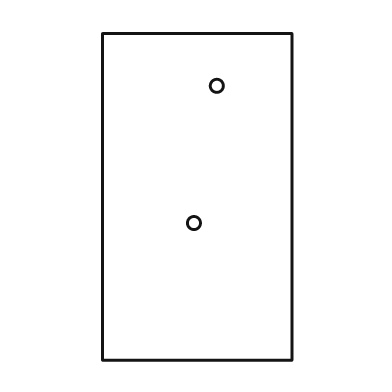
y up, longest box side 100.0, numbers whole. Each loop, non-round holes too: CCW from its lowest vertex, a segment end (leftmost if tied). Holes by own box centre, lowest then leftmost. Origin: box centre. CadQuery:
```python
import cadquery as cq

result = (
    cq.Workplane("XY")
    .moveTo(-29.0, -50.0)
    .lineTo(29.0, -50.0)
    .lineTo(29.0, 50.0)
    .lineTo(-29.0, 50.0)
    .close()
    .moveTo(-1.0, -8.0)
    .circle(2.0)
    .moveTo(6.0, 34.0)
    .circle(2.0)
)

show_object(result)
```